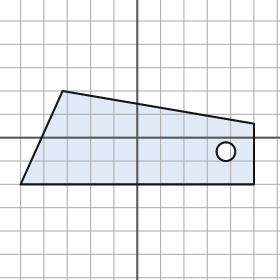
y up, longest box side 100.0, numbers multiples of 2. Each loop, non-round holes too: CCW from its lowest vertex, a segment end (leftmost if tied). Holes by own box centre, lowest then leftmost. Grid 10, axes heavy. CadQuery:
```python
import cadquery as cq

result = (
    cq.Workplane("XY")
    .moveTo(-50.0, -20.0)
    .lineTo(50.0, -20.0)
    .lineTo(50.0, 6.0)
    .lineTo(-32.0, 20.0)
    .close()
    .moveTo(38.0, -6.0)
    .circle(4.0)
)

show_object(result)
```